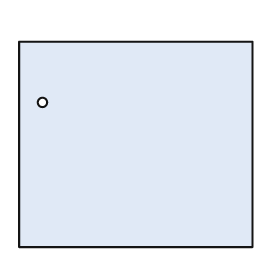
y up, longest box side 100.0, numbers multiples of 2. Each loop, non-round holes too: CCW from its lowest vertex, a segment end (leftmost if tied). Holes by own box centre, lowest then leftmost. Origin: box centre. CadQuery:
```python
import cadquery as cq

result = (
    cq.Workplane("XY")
    .moveTo(-50.0, -44.0)
    .lineTo(50.0, -44.0)
    .lineTo(50.0, 44.0)
    .lineTo(-50.0, 44.0)
    .close()
    .moveTo(-40.0, 18.0)
    .circle(2.0)
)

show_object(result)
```